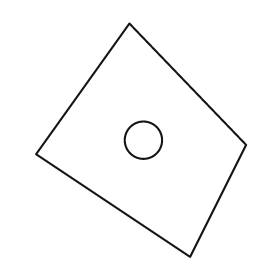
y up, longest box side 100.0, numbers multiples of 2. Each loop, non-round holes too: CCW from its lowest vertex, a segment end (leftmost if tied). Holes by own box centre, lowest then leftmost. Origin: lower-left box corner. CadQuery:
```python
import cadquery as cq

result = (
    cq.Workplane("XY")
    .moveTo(66.0, 0.0)
    .lineTo(90.0, 48.0)
    .lineTo(40.0, 100.0)
    .lineTo(0.0, 44.0)
    .close()
    .moveTo(46.0, 50.0)
    .circle(8.0)
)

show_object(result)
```